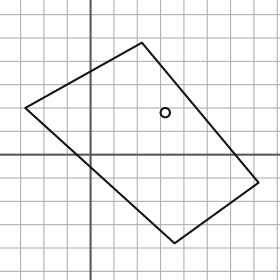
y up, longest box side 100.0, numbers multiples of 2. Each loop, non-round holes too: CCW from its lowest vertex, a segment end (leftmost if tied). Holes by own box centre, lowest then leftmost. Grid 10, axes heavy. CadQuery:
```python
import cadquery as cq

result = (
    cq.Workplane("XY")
    .moveTo(36.0, -38.0)
    .lineTo(72.0, -12.0)
    .lineTo(22.0, 48.0)
    .lineTo(-28.0, 20.0)
    .close()
    .moveTo(32.0, 18.0)
    .circle(2.0)
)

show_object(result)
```